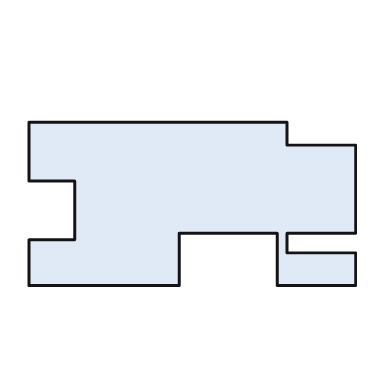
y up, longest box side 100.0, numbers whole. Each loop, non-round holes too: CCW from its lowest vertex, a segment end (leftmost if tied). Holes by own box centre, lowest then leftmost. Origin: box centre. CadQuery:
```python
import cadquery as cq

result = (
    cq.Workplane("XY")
    .moveTo(-50.0, -25.0)
    .lineTo(-4.0, -25.0)
    .lineTo(-4.0, -9.0)
    .lineTo(26.0, -9.0)
    .lineTo(26.0, -25.0)
    .lineTo(50.0, -25.0)
    .lineTo(50.0, -15.0)
    .lineTo(29.0, -15.0)
    .lineTo(29.0, -9.0)
    .lineTo(50.0, -9.0)
    .lineTo(50.0, 18.0)
    .lineTo(29.0, 18.0)
    .lineTo(29.0, 25.0)
    .lineTo(-50.0, 25.0)
    .lineTo(-50.0, 7.0)
    .lineTo(-36.0, 7.0)
    .lineTo(-36.0, -11.0)
    .lineTo(-50.0, -11.0)
    .close()
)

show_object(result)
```